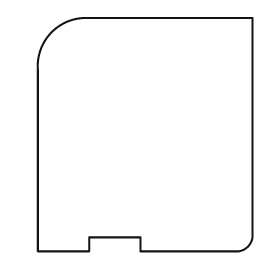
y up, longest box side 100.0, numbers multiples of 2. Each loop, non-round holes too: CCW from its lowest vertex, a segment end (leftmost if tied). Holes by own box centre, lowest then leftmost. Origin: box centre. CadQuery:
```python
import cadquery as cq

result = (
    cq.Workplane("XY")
    .moveTo(-46.0, -50.0)
    .lineTo(-24.0, -50.0)
    .lineTo(-24.0, -44.0)
    .lineTo(-2.0, -44.0)
    .lineTo(-2.0, -50.0)
    .lineTo(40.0, -50.0)
    .threePointArc((44.0, -48.0), (46.0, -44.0))
    .lineTo(46.0, 50.0)
    .lineTo(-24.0, 50.0)
    .threePointArc((-40.0, 44.0), (-46.0, 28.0))
    .close()
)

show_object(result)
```